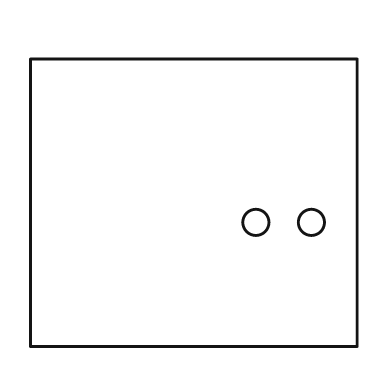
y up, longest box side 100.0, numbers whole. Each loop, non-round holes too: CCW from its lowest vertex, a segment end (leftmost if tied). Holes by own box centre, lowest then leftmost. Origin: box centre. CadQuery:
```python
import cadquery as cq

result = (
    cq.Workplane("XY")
    .moveTo(-50.0, -44.0)
    .lineTo(50.0, -44.0)
    .lineTo(50.0, 44.0)
    .lineTo(-50.0, 44.0)
    .close()
    .moveTo(19.0, -6.0)
    .circle(4.0)
    .moveTo(36.0, -6.0)
    .circle(4.0)
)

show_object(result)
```